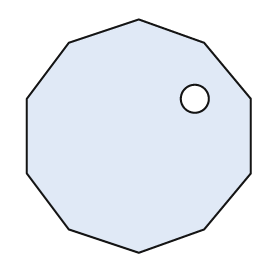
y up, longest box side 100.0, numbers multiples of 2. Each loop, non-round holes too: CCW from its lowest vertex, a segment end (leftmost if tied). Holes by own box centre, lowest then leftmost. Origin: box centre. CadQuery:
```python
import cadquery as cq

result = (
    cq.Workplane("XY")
    .moveTo(0.0, -50.0)
    .lineTo(28.0, -40.0)
    .lineTo(48.0, -16.0)
    .lineTo(48.0, 16.0)
    .lineTo(28.0, 40.0)
    .lineTo(0.0, 50.0)
    .lineTo(-30.0, 40.0)
    .lineTo(-48.0, 16.0)
    .lineTo(-48.0, -16.0)
    .lineTo(-30.0, -40.0)
    .close()
    .moveTo(24.0, 16.0)
    .circle(6.0)
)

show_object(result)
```